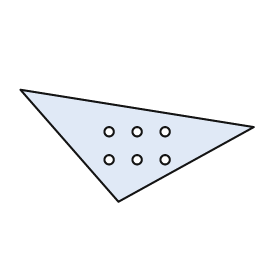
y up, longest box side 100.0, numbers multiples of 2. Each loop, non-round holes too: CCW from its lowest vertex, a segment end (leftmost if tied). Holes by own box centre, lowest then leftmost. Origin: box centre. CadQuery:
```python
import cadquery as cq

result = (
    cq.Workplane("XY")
    .moveTo(-8.0, -24.0)
    .lineTo(50.0, 8.0)
    .lineTo(-50.0, 24.0)
    .close()
    .moveTo(-12.0, -6.0)
    .circle(2.0)
    .moveTo(0.0, -6.0)
    .circle(2.0)
    .moveTo(12.0, -6.0)
    .circle(2.0)
    .moveTo(-12.0, 6.0)
    .circle(2.0)
    .moveTo(0.0, 6.0)
    .circle(2.0)
    .moveTo(12.0, 6.0)
    .circle(2.0)
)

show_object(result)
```